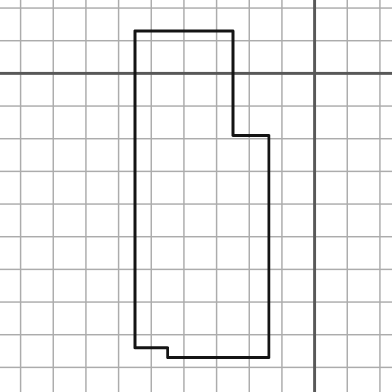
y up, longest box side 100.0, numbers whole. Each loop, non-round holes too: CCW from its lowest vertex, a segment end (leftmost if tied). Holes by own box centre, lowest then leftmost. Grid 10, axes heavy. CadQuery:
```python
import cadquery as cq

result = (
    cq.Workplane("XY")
    .moveTo(-45.0, -87.0)
    .lineTo(-14.0, -87.0)
    .lineTo(-14.0, -19.0)
    .lineTo(-25.0, -19.0)
    .lineTo(-25.0, 13.0)
    .lineTo(-55.0, 13.0)
    .lineTo(-55.0, -84.0)
    .lineTo(-45.0, -84.0)
    .close()
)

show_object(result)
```